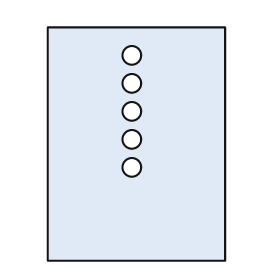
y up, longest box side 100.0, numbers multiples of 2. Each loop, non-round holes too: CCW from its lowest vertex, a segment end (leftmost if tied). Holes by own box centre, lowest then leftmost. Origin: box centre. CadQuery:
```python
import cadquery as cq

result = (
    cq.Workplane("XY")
    .moveTo(-38.0, -50.0)
    .lineTo(38.0, -50.0)
    .lineTo(38.0, 50.0)
    .lineTo(-38.0, 50.0)
    .close()
    .moveTo(-2.0, -10.0)
    .circle(4.0)
    .moveTo(-2.0, 2.0)
    .circle(4.0)
    .moveTo(-2.0, 14.0)
    .circle(4.0)
    .moveTo(-2.0, 26.0)
    .circle(4.0)
    .moveTo(-2.0, 38.0)
    .circle(4.0)
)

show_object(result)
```